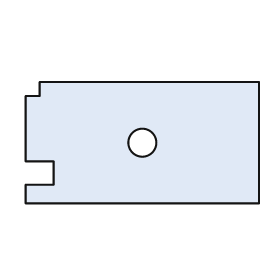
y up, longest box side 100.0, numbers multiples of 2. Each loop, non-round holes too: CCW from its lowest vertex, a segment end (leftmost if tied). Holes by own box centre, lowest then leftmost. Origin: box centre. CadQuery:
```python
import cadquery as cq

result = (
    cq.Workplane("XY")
    .moveTo(-50.0, -26.0)
    .lineTo(50.0, -26.0)
    .lineTo(50.0, 26.0)
    .lineTo(-44.0, 26.0)
    .lineTo(-44.0, 20.0)
    .lineTo(-50.0, 20.0)
    .lineTo(-50.0, -8.0)
    .lineTo(-38.0, -8.0)
    .lineTo(-38.0, -18.0)
    .lineTo(-50.0, -18.0)
    .close()
    .moveTo(0.0, 0.0)
    .circle(6.0)
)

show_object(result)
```